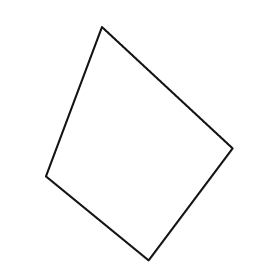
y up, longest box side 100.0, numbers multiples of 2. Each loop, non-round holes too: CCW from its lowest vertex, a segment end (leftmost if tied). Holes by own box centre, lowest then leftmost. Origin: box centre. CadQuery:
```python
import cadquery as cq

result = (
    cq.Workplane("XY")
    .moveTo(4.0, -50.0)
    .lineTo(40.0, -2.0)
    .lineTo(-16.0, 50.0)
    .lineTo(-40.0, -14.0)
    .close()
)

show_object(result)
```